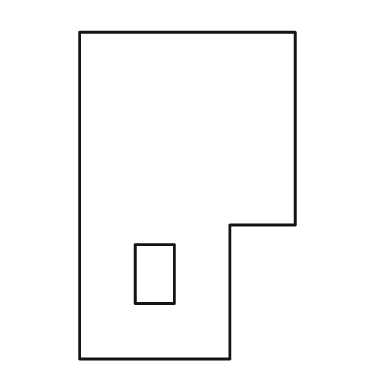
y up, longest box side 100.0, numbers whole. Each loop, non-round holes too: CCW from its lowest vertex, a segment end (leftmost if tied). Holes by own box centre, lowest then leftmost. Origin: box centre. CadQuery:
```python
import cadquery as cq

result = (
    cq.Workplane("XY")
    .moveTo(-33.0, -50.0)
    .lineTo(13.0, -50.0)
    .lineTo(13.0, -9.0)
    .lineTo(33.0, -9.0)
    .lineTo(33.0, 50.0)
    .lineTo(-33.0, 50.0)
    .close()
    .moveTo(-16.0, -33.0)
    .lineTo(-4.0, -33.0)
    .lineTo(-4.0, -15.0)
    .lineTo(-16.0, -15.0)
    .close()
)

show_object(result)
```